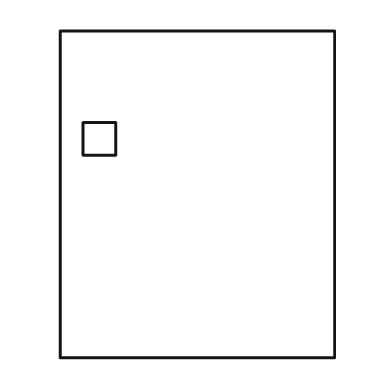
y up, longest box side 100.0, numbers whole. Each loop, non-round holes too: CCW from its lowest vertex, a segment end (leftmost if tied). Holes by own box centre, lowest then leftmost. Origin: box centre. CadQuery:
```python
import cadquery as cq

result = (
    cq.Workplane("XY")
    .moveTo(-42.0, -50.0)
    .lineTo(42.0, -50.0)
    .lineTo(42.0, 50.0)
    .lineTo(-42.0, 50.0)
    .close()
    .moveTo(-35.0, 12.0)
    .lineTo(-25.0, 12.0)
    .lineTo(-25.0, 22.0)
    .lineTo(-35.0, 22.0)
    .close()
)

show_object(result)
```